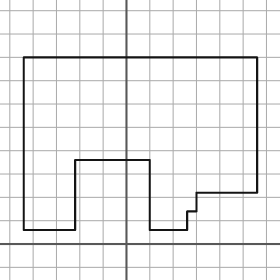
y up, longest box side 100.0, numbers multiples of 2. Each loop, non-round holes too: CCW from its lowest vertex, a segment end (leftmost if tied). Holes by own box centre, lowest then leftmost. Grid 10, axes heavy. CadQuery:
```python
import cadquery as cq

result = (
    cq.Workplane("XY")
    .moveTo(-44.0, 6.0)
    .lineTo(-22.0, 6.0)
    .lineTo(-22.0, 36.0)
    .lineTo(10.0, 36.0)
    .lineTo(10.0, 6.0)
    .lineTo(26.0, 6.0)
    .lineTo(26.0, 14.0)
    .lineTo(30.0, 14.0)
    .lineTo(30.0, 22.0)
    .lineTo(56.0, 22.0)
    .lineTo(56.0, 80.0)
    .lineTo(-44.0, 80.0)
    .close()
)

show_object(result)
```